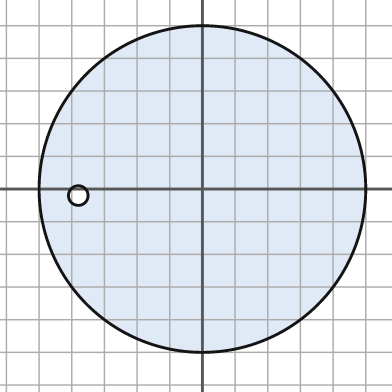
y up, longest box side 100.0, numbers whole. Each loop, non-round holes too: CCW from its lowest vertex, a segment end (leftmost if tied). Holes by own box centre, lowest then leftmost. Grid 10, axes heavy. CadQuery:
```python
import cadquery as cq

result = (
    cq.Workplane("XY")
    .moveTo(0.0, 0.0)
    .circle(50.0)
    .moveTo(-38.0, -2.0)
    .circle(3.0)
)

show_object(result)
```